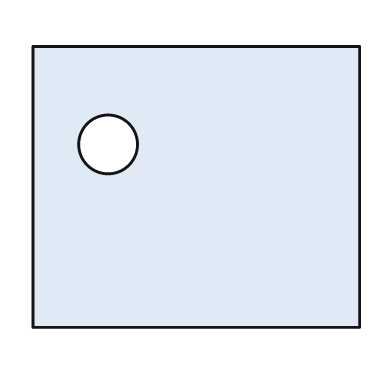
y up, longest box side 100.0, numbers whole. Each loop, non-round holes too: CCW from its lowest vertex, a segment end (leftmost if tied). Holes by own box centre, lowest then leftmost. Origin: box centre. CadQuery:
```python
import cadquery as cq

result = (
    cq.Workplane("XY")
    .moveTo(-50.0, -43.0)
    .lineTo(50.0, -43.0)
    .lineTo(50.0, 43.0)
    .lineTo(-50.0, 43.0)
    .close()
    .moveTo(-27.0, 13.0)
    .circle(9.0)
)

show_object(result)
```